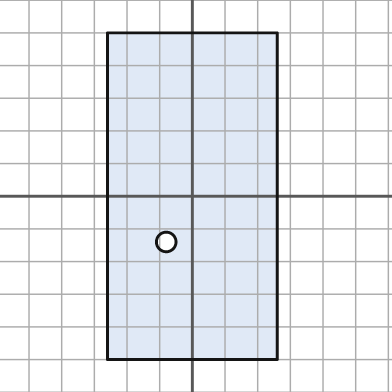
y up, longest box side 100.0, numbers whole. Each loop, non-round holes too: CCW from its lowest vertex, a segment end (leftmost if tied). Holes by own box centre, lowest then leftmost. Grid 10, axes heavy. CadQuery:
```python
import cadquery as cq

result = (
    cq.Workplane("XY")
    .moveTo(-26.0, -50.0)
    .lineTo(26.0, -50.0)
    .lineTo(26.0, 50.0)
    .lineTo(-26.0, 50.0)
    .close()
    .moveTo(-8.0, -14.0)
    .circle(3.0)
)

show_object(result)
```